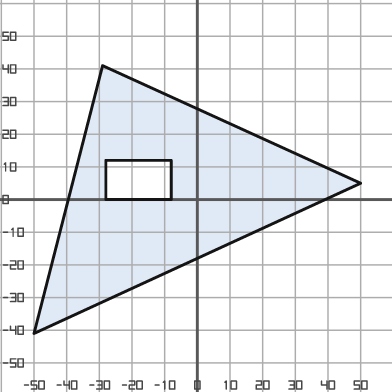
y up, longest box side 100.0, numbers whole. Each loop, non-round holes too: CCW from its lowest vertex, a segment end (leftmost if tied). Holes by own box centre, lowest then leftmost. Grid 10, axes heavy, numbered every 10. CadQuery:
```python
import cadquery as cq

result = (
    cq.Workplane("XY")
    .moveTo(-50.0, -41.0)
    .lineTo(50.0, 5.0)
    .lineTo(-29.0, 41.0)
    .close()
    .moveTo(-28.0, 0.0)
    .lineTo(-8.0, 0.0)
    .lineTo(-8.0, 12.0)
    .lineTo(-28.0, 12.0)
    .close()
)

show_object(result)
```